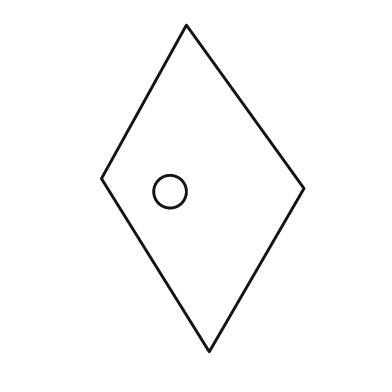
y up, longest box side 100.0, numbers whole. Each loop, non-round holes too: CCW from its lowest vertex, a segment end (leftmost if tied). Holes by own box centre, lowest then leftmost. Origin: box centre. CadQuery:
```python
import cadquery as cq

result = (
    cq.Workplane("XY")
    .moveTo(2.0, -50.0)
    .lineTo(31.0, 0.0)
    .lineTo(-5.0, 50.0)
    .lineTo(-31.0, 3.0)
    .close()
    .moveTo(-10.0, -1.0)
    .circle(5.0)
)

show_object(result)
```